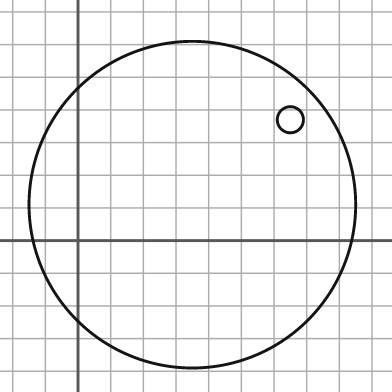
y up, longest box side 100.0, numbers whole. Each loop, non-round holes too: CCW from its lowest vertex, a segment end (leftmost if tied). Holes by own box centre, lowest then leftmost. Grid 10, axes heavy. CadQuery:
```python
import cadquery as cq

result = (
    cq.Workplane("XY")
    .moveTo(35.0, 11.0)
    .circle(50.0)
    .moveTo(65.0, 37.0)
    .circle(4.0)
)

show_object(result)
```